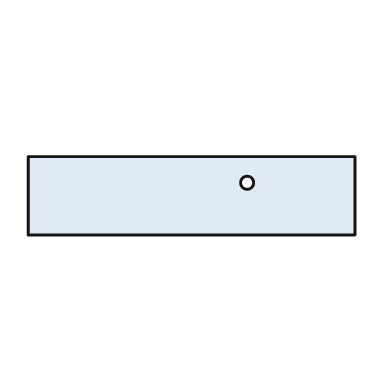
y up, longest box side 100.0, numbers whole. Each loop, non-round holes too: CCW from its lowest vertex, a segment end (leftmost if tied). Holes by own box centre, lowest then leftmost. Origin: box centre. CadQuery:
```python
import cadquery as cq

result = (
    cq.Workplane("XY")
    .moveTo(-50.0, -12.0)
    .lineTo(50.0, -12.0)
    .lineTo(50.0, 12.0)
    .lineTo(-50.0, 12.0)
    .close()
    .moveTo(17.0, 4.0)
    .circle(2.0)
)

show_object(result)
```